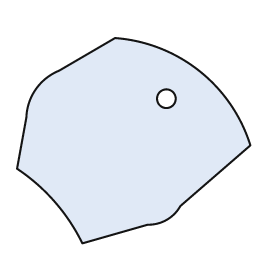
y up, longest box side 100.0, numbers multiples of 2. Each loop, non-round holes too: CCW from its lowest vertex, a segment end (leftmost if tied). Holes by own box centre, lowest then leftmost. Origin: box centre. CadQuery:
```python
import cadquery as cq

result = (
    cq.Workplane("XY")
    .moveTo(-22.0, -44.0)
    .lineTo(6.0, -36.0)
    .threePointArc((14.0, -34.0), (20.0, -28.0))
    .lineTo(50.0, -2.0)
    .threePointArc((28.0, 30.0), (-8.0, 44.0))
    .lineTo(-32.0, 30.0)
    .threePointArc((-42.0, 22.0), (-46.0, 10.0))
    .lineTo(-50.0, -12.0)
    .threePointArc((-34.0, -26.0), (-22.0, -44.0))
    .close()
    .moveTo(14.0, 18.0)
    .circle(4.0)
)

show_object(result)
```